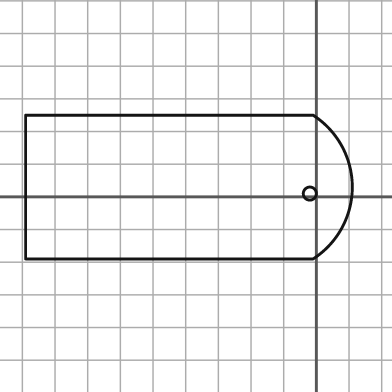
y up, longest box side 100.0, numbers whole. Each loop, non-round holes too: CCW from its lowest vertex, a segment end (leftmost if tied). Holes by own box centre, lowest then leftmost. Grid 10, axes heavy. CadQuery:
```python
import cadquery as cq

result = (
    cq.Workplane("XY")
    .moveTo(-89.0, -19.0)
    .lineTo(-1.0, -19.0)
    .threePointArc((11.0, 3.0), (-1.0, 25.0))
    .lineTo(-89.0, 25.0)
    .close()
    .moveTo(-2.0, 1.0)
    .circle(2.0)
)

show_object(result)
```